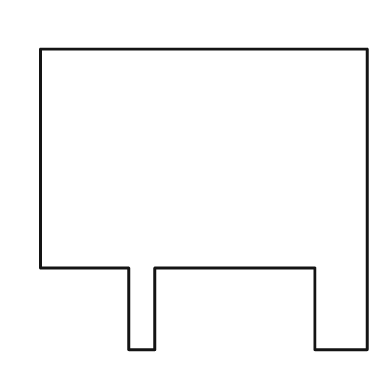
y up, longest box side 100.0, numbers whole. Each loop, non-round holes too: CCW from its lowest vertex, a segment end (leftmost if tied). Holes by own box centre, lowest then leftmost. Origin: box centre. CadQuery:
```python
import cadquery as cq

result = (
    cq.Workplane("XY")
    .moveTo(-23.0, -46.0)
    .lineTo(-15.0, -46.0)
    .lineTo(-15.0, -21.0)
    .lineTo(34.0, -21.0)
    .lineTo(34.0, -46.0)
    .lineTo(50.0, -46.0)
    .lineTo(50.0, 46.0)
    .lineTo(-50.0, 46.0)
    .lineTo(-50.0, -21.0)
    .lineTo(-23.0, -21.0)
    .close()
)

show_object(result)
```